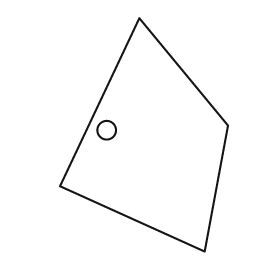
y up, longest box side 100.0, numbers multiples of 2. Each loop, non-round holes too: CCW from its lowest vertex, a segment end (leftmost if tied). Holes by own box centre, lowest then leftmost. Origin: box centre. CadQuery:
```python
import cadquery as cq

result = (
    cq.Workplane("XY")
    .moveTo(26.0, -50.0)
    .lineTo(36.0, 4.0)
    .lineTo(-2.0, 50.0)
    .lineTo(-36.0, -22.0)
    .close()
    .moveTo(-16.0, 2.0)
    .circle(4.0)
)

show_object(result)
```